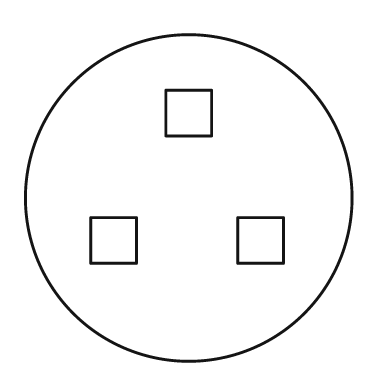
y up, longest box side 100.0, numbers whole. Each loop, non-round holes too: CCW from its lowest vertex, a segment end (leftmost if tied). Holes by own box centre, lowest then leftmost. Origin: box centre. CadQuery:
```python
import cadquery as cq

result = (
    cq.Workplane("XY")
    .moveTo(0.0, 0.0)
    .circle(50.0)
    .moveTo(-30.0, -20.0)
    .lineTo(-16.0, -20.0)
    .lineTo(-16.0, -6.0)
    .lineTo(-30.0, -6.0)
    .close()
    .moveTo(15.0, -20.0)
    .lineTo(29.0, -20.0)
    .lineTo(29.0, -6.0)
    .lineTo(15.0, -6.0)
    .close()
    .moveTo(-7.0, 19.0)
    .lineTo(7.0, 19.0)
    .lineTo(7.0, 33.0)
    .lineTo(-7.0, 33.0)
    .close()
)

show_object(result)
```